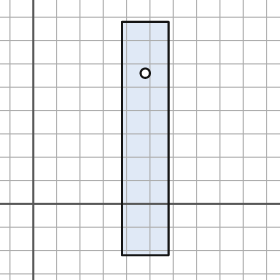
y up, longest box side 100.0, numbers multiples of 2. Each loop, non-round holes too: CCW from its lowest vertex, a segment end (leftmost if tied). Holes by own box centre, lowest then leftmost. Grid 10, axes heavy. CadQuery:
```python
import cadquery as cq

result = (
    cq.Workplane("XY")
    .moveTo(38.0, -22.0)
    .lineTo(58.0, -22.0)
    .lineTo(58.0, 78.0)
    .lineTo(38.0, 78.0)
    .close()
    .moveTo(48.0, 56.0)
    .circle(2.0)
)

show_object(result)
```